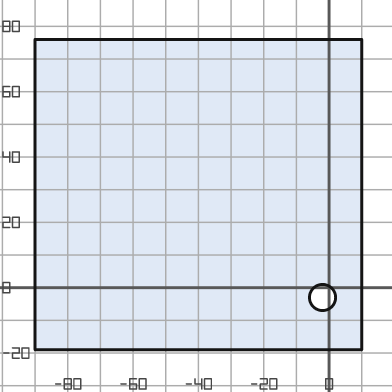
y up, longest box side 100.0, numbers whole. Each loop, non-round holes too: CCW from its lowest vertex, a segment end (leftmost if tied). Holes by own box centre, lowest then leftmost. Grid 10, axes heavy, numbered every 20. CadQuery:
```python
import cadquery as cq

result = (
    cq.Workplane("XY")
    .moveTo(-90.0, -19.0)
    .lineTo(10.0, -19.0)
    .lineTo(10.0, 76.0)
    .lineTo(-90.0, 76.0)
    .close()
    .moveTo(-2.0, -3.0)
    .circle(4.0)
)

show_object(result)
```